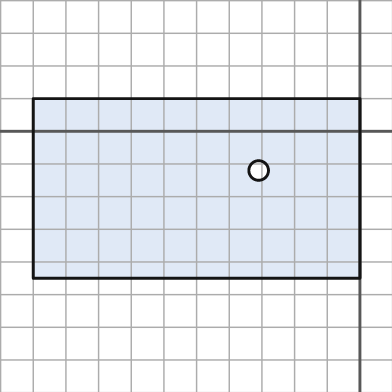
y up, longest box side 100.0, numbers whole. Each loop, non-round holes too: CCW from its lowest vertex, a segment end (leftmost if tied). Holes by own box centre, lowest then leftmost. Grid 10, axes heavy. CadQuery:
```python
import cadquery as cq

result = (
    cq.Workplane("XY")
    .moveTo(-100.0, -45.0)
    .lineTo(0.0, -45.0)
    .lineTo(0.0, 10.0)
    .lineTo(-100.0, 10.0)
    .close()
    .moveTo(-31.0, -12.0)
    .circle(3.0)
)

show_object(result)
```